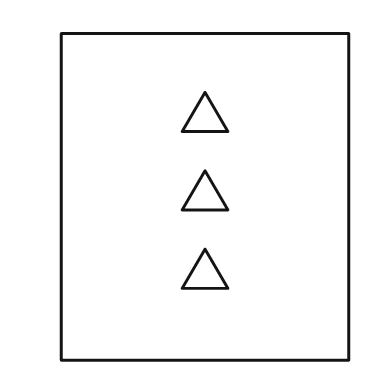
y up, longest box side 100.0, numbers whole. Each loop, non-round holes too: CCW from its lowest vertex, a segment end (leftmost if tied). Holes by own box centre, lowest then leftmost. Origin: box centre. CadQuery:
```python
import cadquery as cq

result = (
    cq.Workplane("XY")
    .moveTo(-44.0, -50.0)
    .lineTo(44.0, -50.0)
    .lineTo(44.0, 50.0)
    .lineTo(-44.0, 50.0)
    .close()
    .moveTo(-7.0, -28.0)
    .lineTo(7.0, -28.0)
    .lineTo(0.0, -16.0)
    .close()
    .moveTo(-7.0, -4.0)
    .lineTo(7.0, -4.0)
    .lineTo(0.0, 8.0)
    .close()
    .moveTo(-7.0, 20.0)
    .lineTo(7.0, 20.0)
    .lineTo(0.0, 32.0)
    .close()
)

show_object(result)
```